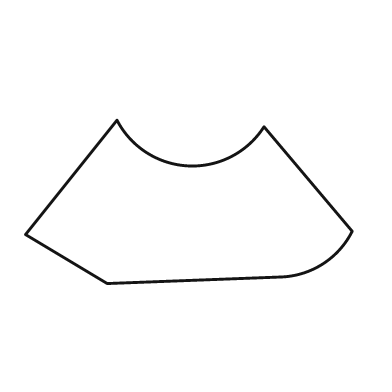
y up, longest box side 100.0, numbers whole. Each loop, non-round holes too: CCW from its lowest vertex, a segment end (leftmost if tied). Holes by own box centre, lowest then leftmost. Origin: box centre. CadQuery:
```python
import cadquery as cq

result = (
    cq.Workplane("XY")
    .moveTo(-25.0, -25.0)
    .lineTo(28.0, -23.0)
    .threePointArc((41.0, -19.0), (50.0, -9.0))
    .lineTo(23.0, 23.0)
    .threePointArc((0.0, 11.0), (-22.0, 25.0))
    .lineTo(-50.0, -10.0)
    .close()
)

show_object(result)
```